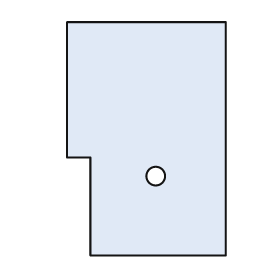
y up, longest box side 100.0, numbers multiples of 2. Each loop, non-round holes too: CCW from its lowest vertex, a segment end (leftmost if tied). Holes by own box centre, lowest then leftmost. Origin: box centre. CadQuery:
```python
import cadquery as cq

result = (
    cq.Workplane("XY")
    .moveTo(-24.0, -50.0)
    .lineTo(34.0, -50.0)
    .lineTo(34.0, 50.0)
    .lineTo(-34.0, 50.0)
    .lineTo(-34.0, -8.0)
    .lineTo(-24.0, -8.0)
    .close()
    .moveTo(4.0, -16.0)
    .circle(4.0)
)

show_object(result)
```